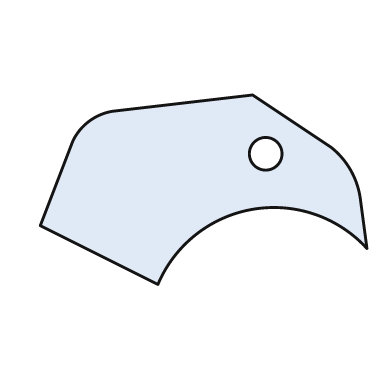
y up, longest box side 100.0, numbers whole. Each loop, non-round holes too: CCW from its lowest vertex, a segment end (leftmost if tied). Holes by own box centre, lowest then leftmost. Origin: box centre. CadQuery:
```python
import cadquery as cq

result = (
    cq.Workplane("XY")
    .moveTo(-14.0, -29.0)
    .threePointArc((15.0, -6.0), (50.0, -18.0))
    .lineTo(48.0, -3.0)
    .threePointArc((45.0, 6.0), (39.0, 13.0))
    .lineTo(15.0, 29.0)
    .lineTo(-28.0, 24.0)
    .threePointArc((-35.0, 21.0), (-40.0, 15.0))
    .lineTo(-50.0, -11.0)
    .close()
    .moveTo(19.0, 11.0)
    .circle(5.0)
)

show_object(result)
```